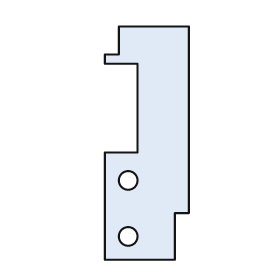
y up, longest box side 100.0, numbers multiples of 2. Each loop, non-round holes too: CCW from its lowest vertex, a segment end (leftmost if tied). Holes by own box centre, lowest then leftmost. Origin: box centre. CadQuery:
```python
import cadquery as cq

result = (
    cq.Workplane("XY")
    .moveTo(-18.0, -50.0)
    .lineTo(12.0, -50.0)
    .lineTo(12.0, -30.0)
    .lineTo(18.0, -30.0)
    .lineTo(18.0, 50.0)
    .lineTo(-12.0, 50.0)
    .lineTo(-12.0, 38.0)
    .lineTo(-18.0, 38.0)
    .lineTo(-18.0, 34.0)
    .lineTo(-4.0, 34.0)
    .lineTo(-4.0, -4.0)
    .lineTo(-18.0, -4.0)
    .close()
    .moveTo(-8.0, -40.0)
    .circle(4.0)
    .moveTo(-8.0, -16.0)
    .circle(4.0)
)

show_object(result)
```